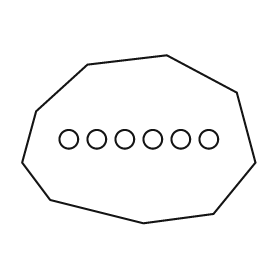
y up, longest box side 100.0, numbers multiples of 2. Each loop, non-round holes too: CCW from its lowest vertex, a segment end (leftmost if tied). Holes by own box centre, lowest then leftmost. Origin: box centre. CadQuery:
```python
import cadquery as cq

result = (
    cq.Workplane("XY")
    .moveTo(2.0, -36.0)
    .lineTo(32.0, -32.0)
    .lineTo(50.0, -10.0)
    .lineTo(42.0, 20.0)
    .lineTo(12.0, 36.0)
    .lineTo(-22.0, 32.0)
    .lineTo(-44.0, 12.0)
    .lineTo(-50.0, -10.0)
    .lineTo(-38.0, -26.0)
    .close()
    .moveTo(-30.0, 0.0)
    .circle(4.0)
    .moveTo(-18.0, 0.0)
    .circle(4.0)
    .moveTo(-6.0, 0.0)
    .circle(4.0)
    .moveTo(6.0, 0.0)
    .circle(4.0)
    .moveTo(18.0, 0.0)
    .circle(4.0)
    .moveTo(30.0, 0.0)
    .circle(4.0)
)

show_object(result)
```